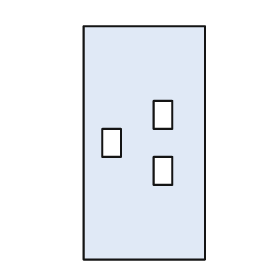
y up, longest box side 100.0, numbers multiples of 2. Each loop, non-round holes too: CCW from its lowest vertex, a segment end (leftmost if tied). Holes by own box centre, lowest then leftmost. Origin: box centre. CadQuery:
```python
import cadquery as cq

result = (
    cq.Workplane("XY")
    .moveTo(-26.0, -50.0)
    .lineTo(26.0, -50.0)
    .lineTo(26.0, 50.0)
    .lineTo(-26.0, 50.0)
    .close()
    .moveTo(4.0, -18.0)
    .lineTo(12.0, -18.0)
    .lineTo(12.0, -6.0)
    .lineTo(4.0, -6.0)
    .close()
    .moveTo(-18.0, -6.0)
    .lineTo(-10.0, -6.0)
    .lineTo(-10.0, 6.0)
    .lineTo(-18.0, 6.0)
    .close()
    .moveTo(4.0, 6.0)
    .lineTo(12.0, 6.0)
    .lineTo(12.0, 18.0)
    .lineTo(4.0, 18.0)
    .close()
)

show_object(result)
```